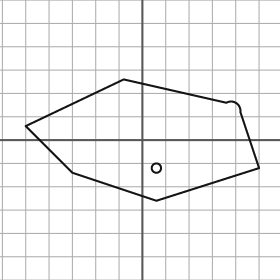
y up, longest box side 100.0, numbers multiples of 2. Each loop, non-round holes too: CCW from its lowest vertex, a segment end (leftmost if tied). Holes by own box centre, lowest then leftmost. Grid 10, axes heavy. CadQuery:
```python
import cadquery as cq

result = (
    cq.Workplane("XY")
    .moveTo(6.0, -26.0)
    .lineTo(50.0, -12.0)
    .lineTo(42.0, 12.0)
    .threePointArc((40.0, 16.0), (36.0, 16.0))
    .lineTo(-8.0, 26.0)
    .lineTo(-50.0, 6.0)
    .lineTo(-30.0, -14.0)
    .close()
    .moveTo(6.0, -12.0)
    .circle(2.0)
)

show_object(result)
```